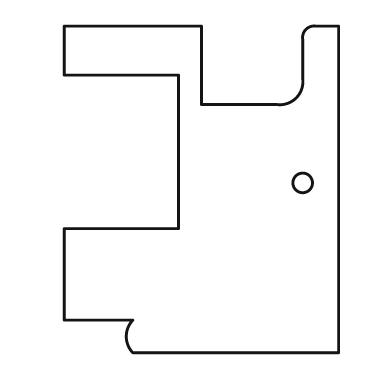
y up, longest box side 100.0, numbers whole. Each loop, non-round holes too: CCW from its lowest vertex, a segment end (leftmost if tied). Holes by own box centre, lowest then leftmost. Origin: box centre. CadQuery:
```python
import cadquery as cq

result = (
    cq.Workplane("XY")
    .moveTo(-21.0, -50.0)
    .lineTo(42.0, -50.0)
    .lineTo(42.0, 50.0)
    .lineTo(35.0, 50.0)
    .threePointArc((32.0, 49.0), (31.0, 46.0))
    .lineTo(31.0, 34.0)
    .threePointArc((29.0, 28.0), (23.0, 26.0))
    .lineTo(0.0, 26.0)
    .lineTo(0.0, 50.0)
    .lineTo(-42.0, 50.0)
    .lineTo(-42.0, 35.0)
    .lineTo(-7.0, 35.0)
    .lineTo(-7.0, -12.0)
    .lineTo(-42.0, -12.0)
    .lineTo(-42.0, -40.0)
    .lineTo(-21.0, -40.0)
    .threePointArc((-23.0, -45.0), (-21.0, -50.0))
    .close()
    .moveTo(31.0, 2.0)
    .circle(3.0)
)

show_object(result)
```